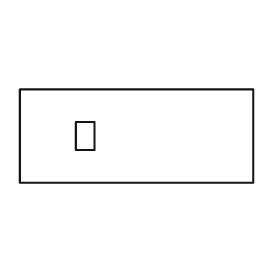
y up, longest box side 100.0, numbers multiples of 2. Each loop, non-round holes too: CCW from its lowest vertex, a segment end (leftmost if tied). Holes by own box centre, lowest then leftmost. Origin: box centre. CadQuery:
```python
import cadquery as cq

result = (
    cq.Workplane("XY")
    .moveTo(-50.0, -20.0)
    .lineTo(50.0, -20.0)
    .lineTo(50.0, 20.0)
    .lineTo(-50.0, 20.0)
    .close()
    .moveTo(-26.0, -6.0)
    .lineTo(-18.0, -6.0)
    .lineTo(-18.0, 6.0)
    .lineTo(-26.0, 6.0)
    .close()
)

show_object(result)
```